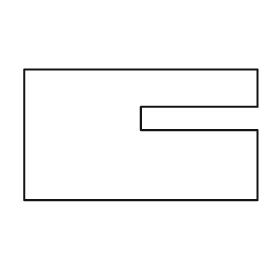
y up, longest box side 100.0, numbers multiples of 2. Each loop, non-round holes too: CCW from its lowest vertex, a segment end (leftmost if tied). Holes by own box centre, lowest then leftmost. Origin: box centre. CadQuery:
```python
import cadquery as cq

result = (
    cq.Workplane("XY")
    .moveTo(-50.0, -28.0)
    .lineTo(50.0, -28.0)
    .lineTo(50.0, 2.0)
    .lineTo(0.0, 2.0)
    .lineTo(0.0, 12.0)
    .lineTo(50.0, 12.0)
    .lineTo(50.0, 28.0)
    .lineTo(-50.0, 28.0)
    .close()
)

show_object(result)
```